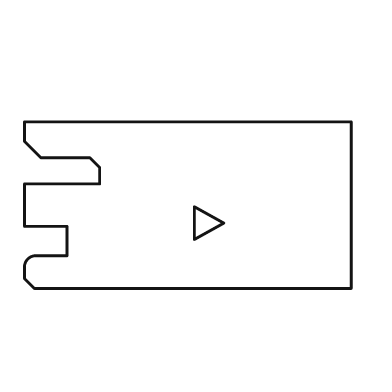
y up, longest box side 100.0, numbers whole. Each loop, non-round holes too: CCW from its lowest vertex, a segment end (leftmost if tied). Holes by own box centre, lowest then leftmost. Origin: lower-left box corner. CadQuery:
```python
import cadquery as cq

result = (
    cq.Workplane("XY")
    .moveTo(3.0, 0.0)
    .lineTo(100.0, 0.0)
    .lineTo(100.0, 51.0)
    .lineTo(0.0, 51.0)
    .lineTo(0.0, 45.0)
    .lineTo(5.0, 40.0)
    .lineTo(20.0, 40.0)
    .lineTo(23.0, 37.0)
    .lineTo(23.0, 32.0)
    .lineTo(0.0, 32.0)
    .lineTo(0.0, 19.0)
    .lineTo(13.0, 19.0)
    .lineTo(13.0, 10.0)
    .lineTo(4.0, 10.0)
    .threePointArc((1.0, 9.0), (0.0, 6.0))
    .lineTo(0.0, 3.0)
    .close()
    .moveTo(52.0, 15.0)
    .lineTo(61.0, 20.0)
    .lineTo(52.0, 25.0)
    .close()
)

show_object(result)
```